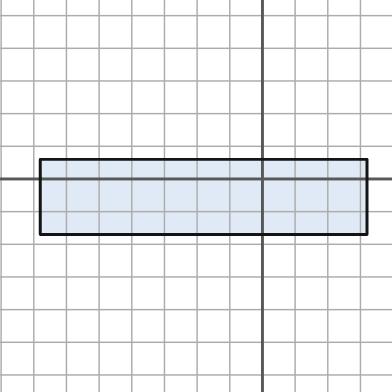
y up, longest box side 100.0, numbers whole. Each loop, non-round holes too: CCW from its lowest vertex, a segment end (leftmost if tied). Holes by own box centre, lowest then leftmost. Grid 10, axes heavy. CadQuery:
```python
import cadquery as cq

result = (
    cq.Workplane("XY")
    .moveTo(-68.0, -17.0)
    .lineTo(32.0, -17.0)
    .lineTo(32.0, 6.0)
    .lineTo(-68.0, 6.0)
    .close()
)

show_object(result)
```